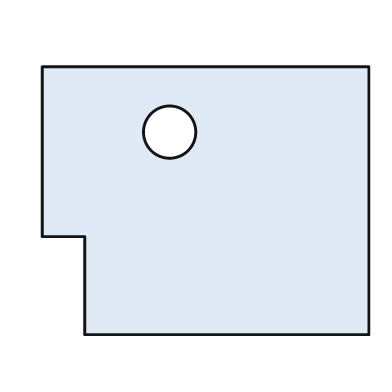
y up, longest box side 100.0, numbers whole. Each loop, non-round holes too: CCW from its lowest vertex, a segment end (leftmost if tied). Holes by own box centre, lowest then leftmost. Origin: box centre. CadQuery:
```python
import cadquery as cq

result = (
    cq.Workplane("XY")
    .moveTo(-37.0, -41.0)
    .lineTo(50.0, -41.0)
    .lineTo(50.0, 41.0)
    .lineTo(-50.0, 41.0)
    .lineTo(-50.0, -11.0)
    .lineTo(-37.0, -11.0)
    .close()
    .moveTo(-11.0, 21.0)
    .circle(8.0)
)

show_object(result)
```